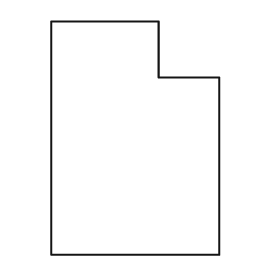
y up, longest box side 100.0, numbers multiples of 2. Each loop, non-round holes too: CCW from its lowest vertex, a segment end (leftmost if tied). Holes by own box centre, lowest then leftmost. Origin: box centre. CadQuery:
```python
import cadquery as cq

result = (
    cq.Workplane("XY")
    .moveTo(-36.0, -50.0)
    .lineTo(36.0, -50.0)
    .lineTo(36.0, 26.0)
    .lineTo(10.0, 26.0)
    .lineTo(10.0, 50.0)
    .lineTo(-36.0, 50.0)
    .close()
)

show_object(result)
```